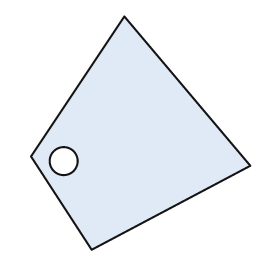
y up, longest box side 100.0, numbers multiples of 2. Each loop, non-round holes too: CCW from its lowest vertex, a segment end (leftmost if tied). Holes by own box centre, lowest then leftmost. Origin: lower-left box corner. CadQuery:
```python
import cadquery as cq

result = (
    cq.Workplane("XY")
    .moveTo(26.0, 0.0)
    .lineTo(94.0, 36.0)
    .lineTo(40.0, 100.0)
    .lineTo(0.0, 40.0)
    .close()
    .moveTo(14.0, 38.0)
    .circle(6.0)
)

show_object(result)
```